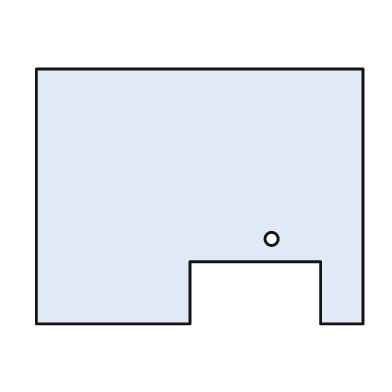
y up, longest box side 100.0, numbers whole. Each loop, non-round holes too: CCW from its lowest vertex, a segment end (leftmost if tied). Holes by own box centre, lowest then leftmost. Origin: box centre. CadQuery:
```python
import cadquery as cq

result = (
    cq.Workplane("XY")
    .moveTo(-50.0, -39.0)
    .lineTo(-3.0, -39.0)
    .lineTo(-3.0, -20.0)
    .lineTo(37.0, -20.0)
    .lineTo(37.0, -39.0)
    .lineTo(50.0, -39.0)
    .lineTo(50.0, 39.0)
    .lineTo(-50.0, 39.0)
    .close()
    .moveTo(22.0, -13.0)
    .circle(2.0)
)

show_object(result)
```